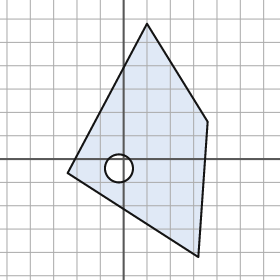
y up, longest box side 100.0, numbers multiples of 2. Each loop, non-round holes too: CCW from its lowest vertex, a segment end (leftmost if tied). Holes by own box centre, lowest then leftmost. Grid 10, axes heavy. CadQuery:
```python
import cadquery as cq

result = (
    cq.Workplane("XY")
    .moveTo(32.0, -42.0)
    .lineTo(36.0, 16.0)
    .lineTo(10.0, 58.0)
    .lineTo(-24.0, -6.0)
    .close()
    .moveTo(-2.0, -4.0)
    .circle(6.0)
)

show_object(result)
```